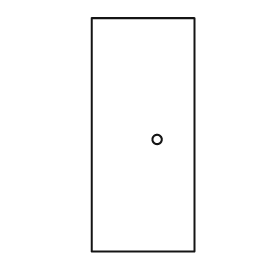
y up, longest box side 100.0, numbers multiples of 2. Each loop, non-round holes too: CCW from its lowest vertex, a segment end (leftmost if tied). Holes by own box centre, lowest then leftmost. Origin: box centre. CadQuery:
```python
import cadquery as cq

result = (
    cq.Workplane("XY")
    .moveTo(-22.0, -50.0)
    .lineTo(22.0, -50.0)
    .lineTo(22.0, 50.0)
    .lineTo(-22.0, 50.0)
    .close()
    .moveTo(6.0, -2.0)
    .circle(2.0)
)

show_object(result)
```